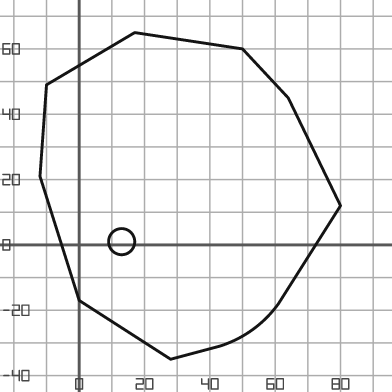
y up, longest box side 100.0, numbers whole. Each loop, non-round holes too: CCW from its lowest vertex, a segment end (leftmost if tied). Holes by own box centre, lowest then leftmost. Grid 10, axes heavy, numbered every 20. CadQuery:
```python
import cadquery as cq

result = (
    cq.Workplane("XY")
    .moveTo(28.0, -35.0)
    .lineTo(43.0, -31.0)
    .threePointArc((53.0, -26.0), (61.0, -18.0))
    .lineTo(80.0, 12.0)
    .lineTo(64.0, 45.0)
    .lineTo(50.0, 60.0)
    .lineTo(17.0, 65.0)
    .lineTo(-10.0, 49.0)
    .lineTo(-12.0, 21.0)
    .lineTo(0.0, -17.0)
    .close()
    .moveTo(13.0, 1.0)
    .circle(4.0)
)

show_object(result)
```